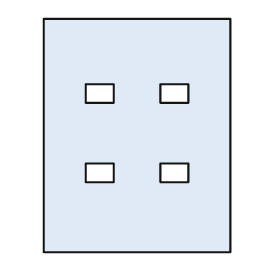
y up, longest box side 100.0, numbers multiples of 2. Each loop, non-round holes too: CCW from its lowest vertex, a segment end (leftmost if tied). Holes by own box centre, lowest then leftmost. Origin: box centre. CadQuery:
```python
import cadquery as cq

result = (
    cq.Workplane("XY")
    .moveTo(-40.0, -50.0)
    .lineTo(40.0, -50.0)
    .lineTo(40.0, 50.0)
    .lineTo(-40.0, 50.0)
    .close()
    .moveTo(-22.0, -20.0)
    .lineTo(-10.0, -20.0)
    .lineTo(-10.0, -12.0)
    .lineTo(-22.0, -12.0)
    .close()
    .moveTo(10.0, -20.0)
    .lineTo(22.0, -20.0)
    .lineTo(22.0, -12.0)
    .lineTo(10.0, -12.0)
    .close()
    .moveTo(-22.0, 14.0)
    .lineTo(-10.0, 14.0)
    .lineTo(-10.0, 22.0)
    .lineTo(-22.0, 22.0)
    .close()
    .moveTo(10.0, 14.0)
    .lineTo(22.0, 14.0)
    .lineTo(22.0, 22.0)
    .lineTo(10.0, 22.0)
    .close()
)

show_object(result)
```